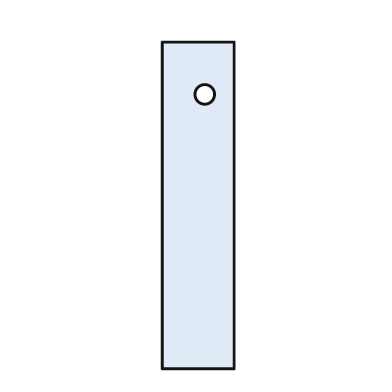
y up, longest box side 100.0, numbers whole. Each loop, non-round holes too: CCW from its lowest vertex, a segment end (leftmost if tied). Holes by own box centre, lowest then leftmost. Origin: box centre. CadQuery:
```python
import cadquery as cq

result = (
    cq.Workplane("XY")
    .moveTo(-11.0, -50.0)
    .lineTo(11.0, -50.0)
    .lineTo(11.0, 50.0)
    .lineTo(-11.0, 50.0)
    .close()
    .moveTo(2.0, 34.0)
    .circle(3.0)
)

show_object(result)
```